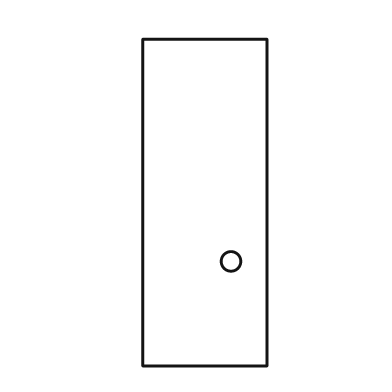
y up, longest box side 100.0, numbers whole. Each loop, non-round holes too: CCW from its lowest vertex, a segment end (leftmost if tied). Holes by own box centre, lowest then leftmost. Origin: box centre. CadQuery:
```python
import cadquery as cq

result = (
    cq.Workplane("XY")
    .moveTo(-19.0, -50.0)
    .lineTo(19.0, -50.0)
    .lineTo(19.0, 50.0)
    .lineTo(-19.0, 50.0)
    .close()
    .moveTo(8.0, -18.0)
    .circle(3.0)
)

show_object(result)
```